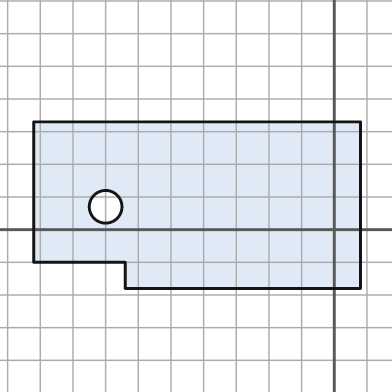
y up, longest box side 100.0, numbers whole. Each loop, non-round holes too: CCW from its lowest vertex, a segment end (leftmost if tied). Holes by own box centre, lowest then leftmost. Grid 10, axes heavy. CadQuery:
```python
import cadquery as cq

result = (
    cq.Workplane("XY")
    .moveTo(-64.0, -18.0)
    .lineTo(8.0, -18.0)
    .lineTo(8.0, 33.0)
    .lineTo(-92.0, 33.0)
    .lineTo(-92.0, -10.0)
    .lineTo(-64.0, -10.0)
    .close()
    .moveTo(-70.0, 7.0)
    .circle(5.0)
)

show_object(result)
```